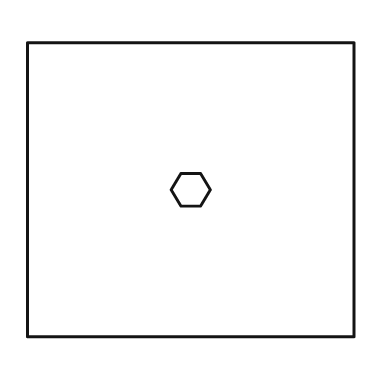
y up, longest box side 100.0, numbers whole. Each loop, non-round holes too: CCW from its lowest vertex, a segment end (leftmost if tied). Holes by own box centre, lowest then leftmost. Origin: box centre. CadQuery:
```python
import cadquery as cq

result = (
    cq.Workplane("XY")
    .moveTo(-50.0, -45.0)
    .lineTo(50.0, -45.0)
    .lineTo(50.0, 45.0)
    .lineTo(-50.0, 45.0)
    .close()
    .moveTo(-3.0, -5.0)
    .lineTo(3.0, -5.0)
    .lineTo(6.0, 0.0)
    .lineTo(3.0, 5.0)
    .lineTo(-3.0, 5.0)
    .lineTo(-6.0, 0.0)
    .close()
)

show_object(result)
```